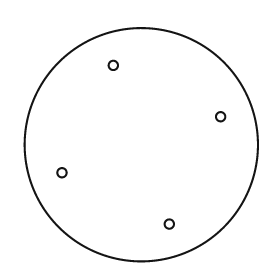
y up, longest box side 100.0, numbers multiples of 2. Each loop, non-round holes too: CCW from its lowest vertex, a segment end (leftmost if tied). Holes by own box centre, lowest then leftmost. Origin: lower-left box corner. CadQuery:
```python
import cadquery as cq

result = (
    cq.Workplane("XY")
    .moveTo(50.0, 50.0)
    .circle(50.0)
    .moveTo(62.0, 16.0)
    .circle(2.0)
    .moveTo(16.0, 38.0)
    .circle(2.0)
    .moveTo(84.0, 62.0)
    .circle(2.0)
    .moveTo(38.0, 84.0)
    .circle(2.0)
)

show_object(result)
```